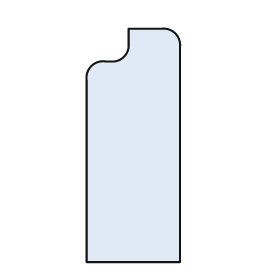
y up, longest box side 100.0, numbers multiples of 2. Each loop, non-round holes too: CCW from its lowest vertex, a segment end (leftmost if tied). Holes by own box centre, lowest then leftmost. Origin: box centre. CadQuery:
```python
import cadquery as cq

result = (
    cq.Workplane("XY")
    .moveTo(-20.0, -50.0)
    .lineTo(20.0, -50.0)
    .lineTo(20.0, 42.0)
    .threePointArc((18.0, 48.0), (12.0, 50.0))
    .lineTo(-2.0, 50.0)
    .lineTo(-2.0, 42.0)
    .threePointArc((-4.0, 38.0), (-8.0, 36.0))
    .lineTo(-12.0, 36.0)
    .threePointArc((-18.0, 34.0), (-20.0, 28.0))
    .close()
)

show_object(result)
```